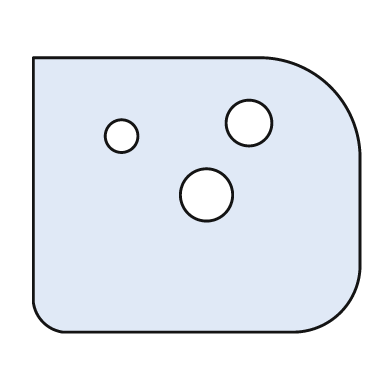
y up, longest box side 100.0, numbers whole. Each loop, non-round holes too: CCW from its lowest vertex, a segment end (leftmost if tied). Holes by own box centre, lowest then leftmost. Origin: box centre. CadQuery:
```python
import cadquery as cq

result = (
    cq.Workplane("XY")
    .moveTo(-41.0, -42.0)
    .lineTo(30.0, -42.0)
    .threePointArc((44.0, -36.0), (50.0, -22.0))
    .lineTo(50.0, 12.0)
    .threePointArc((41.0, 33.0), (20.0, 42.0))
    .lineTo(-50.0, 42.0)
    .lineTo(-50.0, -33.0)
    .threePointArc((-47.0, -39.0), (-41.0, -42.0))
    .close()
    .moveTo(3.0, 0.0)
    .circle(8.0)
    .moveTo(-23.0, 18.0)
    .circle(5.0)
    .moveTo(16.0, 22.0)
    .circle(7.0)
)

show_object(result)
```